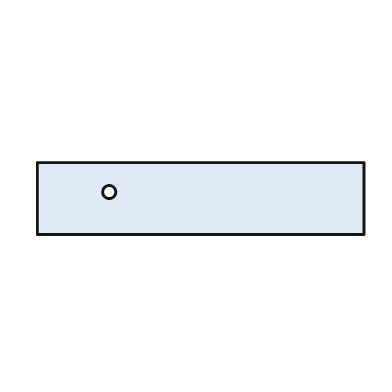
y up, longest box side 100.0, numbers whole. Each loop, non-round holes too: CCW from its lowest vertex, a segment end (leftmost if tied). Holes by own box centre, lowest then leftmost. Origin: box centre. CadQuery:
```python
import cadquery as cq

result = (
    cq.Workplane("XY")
    .moveTo(-50.0, -11.0)
    .lineTo(50.0, -11.0)
    .lineTo(50.0, 11.0)
    .lineTo(-50.0, 11.0)
    .close()
    .moveTo(-28.0, 2.0)
    .circle(2.0)
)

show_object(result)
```